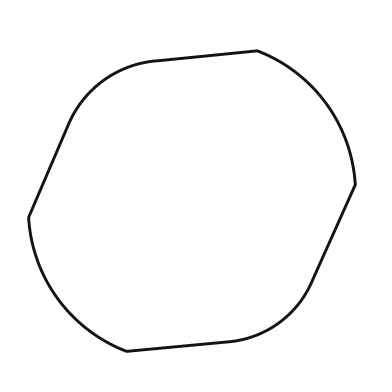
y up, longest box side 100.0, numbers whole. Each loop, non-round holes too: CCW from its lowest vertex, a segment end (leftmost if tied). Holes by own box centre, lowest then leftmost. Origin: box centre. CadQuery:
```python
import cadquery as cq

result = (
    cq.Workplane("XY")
    .moveTo(-20.0, -46.0)
    .lineTo(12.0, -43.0)
    .threePointArc((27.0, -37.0), (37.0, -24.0))
    .lineTo(50.0, 5.0)
    .threePointArc((41.0, 30.0), (20.0, 46.0))
    .lineTo(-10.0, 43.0)
    .threePointArc((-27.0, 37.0), (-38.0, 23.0))
    .lineTo(-50.0, -5.0)
    .threePointArc((-41.0, -30.0), (-20.0, -46.0))
    .close()
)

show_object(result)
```